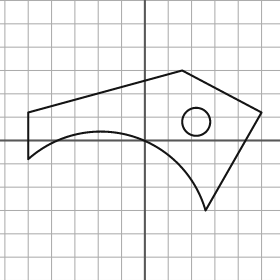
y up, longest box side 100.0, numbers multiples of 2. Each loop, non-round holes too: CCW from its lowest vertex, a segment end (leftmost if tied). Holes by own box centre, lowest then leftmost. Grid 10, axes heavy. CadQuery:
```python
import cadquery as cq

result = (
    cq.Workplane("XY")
    .moveTo(26.0, -30.0)
    .lineTo(50.0, 12.0)
    .lineTo(16.0, 30.0)
    .lineTo(-50.0, 12.0)
    .lineTo(-50.0, -8.0)
    .threePointArc((-6.0, 2.0), (26.0, -30.0))
    .close()
    .moveTo(22.0, 8.0)
    .circle(6.0)
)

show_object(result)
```